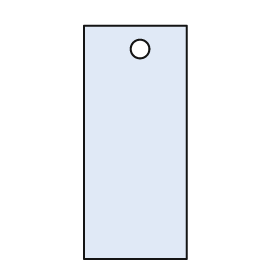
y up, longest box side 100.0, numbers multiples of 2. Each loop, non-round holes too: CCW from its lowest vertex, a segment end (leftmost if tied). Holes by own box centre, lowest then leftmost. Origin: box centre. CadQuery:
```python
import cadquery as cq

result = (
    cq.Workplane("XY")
    .moveTo(-22.0, -50.0)
    .lineTo(22.0, -50.0)
    .lineTo(22.0, 50.0)
    .lineTo(-22.0, 50.0)
    .close()
    .moveTo(2.0, 40.0)
    .circle(4.0)
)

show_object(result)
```